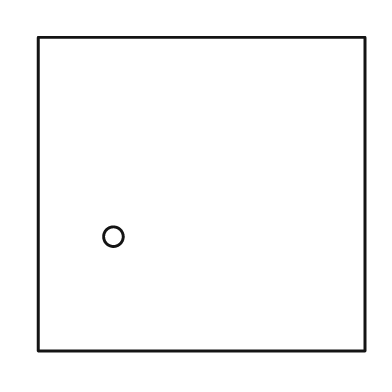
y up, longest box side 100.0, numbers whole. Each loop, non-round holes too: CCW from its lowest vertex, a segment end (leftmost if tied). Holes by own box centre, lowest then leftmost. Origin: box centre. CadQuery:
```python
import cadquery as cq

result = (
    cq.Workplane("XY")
    .moveTo(-50.0, -48.0)
    .lineTo(50.0, -48.0)
    .lineTo(50.0, 48.0)
    .lineTo(-50.0, 48.0)
    .close()
    .moveTo(-27.0, -13.0)
    .circle(3.0)
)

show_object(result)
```